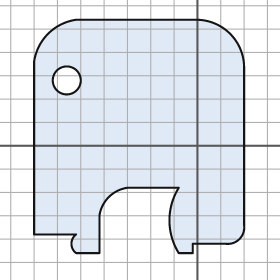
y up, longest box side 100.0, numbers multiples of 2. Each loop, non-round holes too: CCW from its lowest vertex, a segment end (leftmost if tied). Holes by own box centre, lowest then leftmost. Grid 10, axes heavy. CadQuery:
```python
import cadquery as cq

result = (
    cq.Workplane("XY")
    .moveTo(-52.0, -46.0)
    .lineTo(-42.0, -46.0)
    .lineTo(-42.0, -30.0)
    .threePointArc((-38.0, -22.0), (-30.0, -18.0))
    .lineTo(-8.0, -18.0)
    .threePointArc((-12.0, -32.0), (-8.0, -46.0))
    .lineTo(-2.0, -46.0)
    .lineTo(-2.0, -42.0)
    .lineTo(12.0, -42.0)
    .threePointArc((18.0, -40.0), (20.0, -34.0))
    .lineTo(20.0, 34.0)
    .threePointArc((14.0, 48.0), (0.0, 54.0))
    .lineTo(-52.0, 54.0)
    .threePointArc((-64.0, 48.0), (-70.0, 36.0))
    .lineTo(-70.0, -38.0)
    .lineTo(-52.0, -38.0)
    .threePointArc((-54.0, -42.0), (-52.0, -46.0))
    .close()
    .moveTo(-56.0, 28.0)
    .circle(6.0)
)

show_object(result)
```